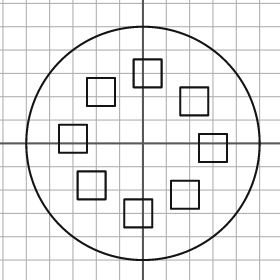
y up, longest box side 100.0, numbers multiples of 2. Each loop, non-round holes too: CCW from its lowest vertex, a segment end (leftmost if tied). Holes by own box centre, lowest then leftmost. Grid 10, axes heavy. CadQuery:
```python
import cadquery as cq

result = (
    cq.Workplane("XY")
    .moveTo(0.0, 0.0)
    .circle(50.0)
    .moveTo(-8.0, -36.0)
    .lineTo(4.0, -36.0)
    .lineTo(4.0, -24.0)
    .lineTo(-8.0, -24.0)
    .close()
    .moveTo(12.0, -28.0)
    .lineTo(24.0, -28.0)
    .lineTo(24.0, -16.0)
    .lineTo(12.0, -16.0)
    .close()
    .moveTo(-28.0, -24.0)
    .lineTo(-16.0, -24.0)
    .lineTo(-16.0, -12.0)
    .lineTo(-28.0, -12.0)
    .close()
    .moveTo(24.0, -8.0)
    .lineTo(36.0, -8.0)
    .lineTo(36.0, 4.0)
    .lineTo(24.0, 4.0)
    .close()
    .moveTo(-36.0, -4.0)
    .lineTo(-24.0, -4.0)
    .lineTo(-24.0, 8.0)
    .lineTo(-36.0, 8.0)
    .close()
    .moveTo(16.0, 12.0)
    .lineTo(28.0, 12.0)
    .lineTo(28.0, 24.0)
    .lineTo(16.0, 24.0)
    .close()
    .moveTo(-24.0, 16.0)
    .lineTo(-12.0, 16.0)
    .lineTo(-12.0, 28.0)
    .lineTo(-24.0, 28.0)
    .close()
    .moveTo(-4.0, 24.0)
    .lineTo(8.0, 24.0)
    .lineTo(8.0, 36.0)
    .lineTo(-4.0, 36.0)
    .close()
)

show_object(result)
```